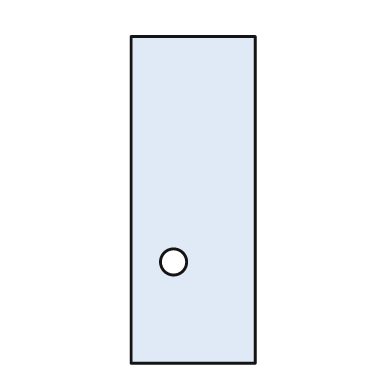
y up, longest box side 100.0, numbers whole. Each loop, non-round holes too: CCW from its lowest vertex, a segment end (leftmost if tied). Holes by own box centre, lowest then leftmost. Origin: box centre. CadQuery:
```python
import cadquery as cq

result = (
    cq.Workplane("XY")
    .moveTo(-19.0, -50.0)
    .lineTo(19.0, -50.0)
    .lineTo(19.0, 50.0)
    .lineTo(-19.0, 50.0)
    .close()
    .moveTo(-6.0, -19.0)
    .circle(4.0)
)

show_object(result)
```